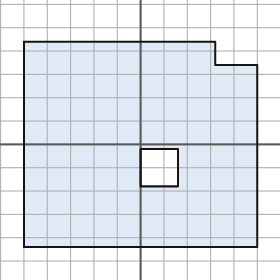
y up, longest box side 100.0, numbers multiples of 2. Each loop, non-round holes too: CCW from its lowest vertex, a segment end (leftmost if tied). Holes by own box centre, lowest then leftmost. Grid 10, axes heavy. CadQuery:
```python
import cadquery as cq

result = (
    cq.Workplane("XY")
    .moveTo(-50.0, -44.0)
    .lineTo(50.0, -44.0)
    .lineTo(50.0, 34.0)
    .lineTo(32.0, 34.0)
    .lineTo(32.0, 44.0)
    .lineTo(-50.0, 44.0)
    .close()
    .moveTo(0.0, -18.0)
    .lineTo(16.0, -18.0)
    .lineTo(16.0, -2.0)
    .lineTo(0.0, -2.0)
    .close()
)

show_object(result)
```